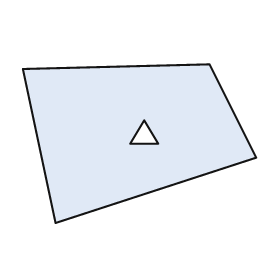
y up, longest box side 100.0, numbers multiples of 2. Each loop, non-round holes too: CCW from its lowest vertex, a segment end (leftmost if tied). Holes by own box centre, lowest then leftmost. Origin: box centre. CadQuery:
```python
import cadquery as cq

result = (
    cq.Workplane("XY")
    .moveTo(-36.0, -34.0)
    .lineTo(50.0, -6.0)
    .lineTo(30.0, 34.0)
    .lineTo(-50.0, 32.0)
    .close()
    .moveTo(-4.0, 0.0)
    .lineTo(8.0, 0.0)
    .lineTo(2.0, 10.0)
    .close()
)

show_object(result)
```